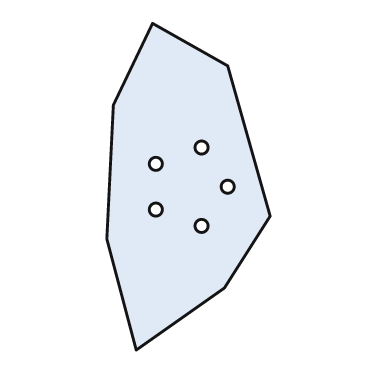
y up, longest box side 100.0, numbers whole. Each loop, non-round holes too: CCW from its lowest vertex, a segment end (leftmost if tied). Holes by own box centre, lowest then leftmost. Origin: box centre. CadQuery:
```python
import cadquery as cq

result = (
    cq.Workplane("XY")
    .moveTo(-16.0, -50.0)
    .lineTo(11.0, -31.0)
    .lineTo(25.0, -9.0)
    .lineTo(12.0, 37.0)
    .lineTo(-11.0, 50.0)
    .lineTo(-23.0, 25.0)
    .lineTo(-25.0, -16.0)
    .close()
    .moveTo(4.0, -12.0)
    .circle(2.0)
    .moveTo(-10.0, -7.0)
    .circle(2.0)
    .moveTo(12.0, 0.0)
    .circle(2.0)
    .moveTo(-10.0, 7.0)
    .circle(2.0)
    .moveTo(4.0, 12.0)
    .circle(2.0)
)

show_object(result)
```